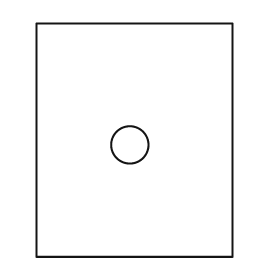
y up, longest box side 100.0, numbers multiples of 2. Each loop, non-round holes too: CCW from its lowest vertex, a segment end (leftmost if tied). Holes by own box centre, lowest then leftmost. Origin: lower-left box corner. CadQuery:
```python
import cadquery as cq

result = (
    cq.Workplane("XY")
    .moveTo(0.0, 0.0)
    .lineTo(84.0, 0.0)
    .lineTo(84.0, 100.0)
    .lineTo(0.0, 100.0)
    .close()
    .moveTo(40.0, 48.0)
    .circle(8.0)
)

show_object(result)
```